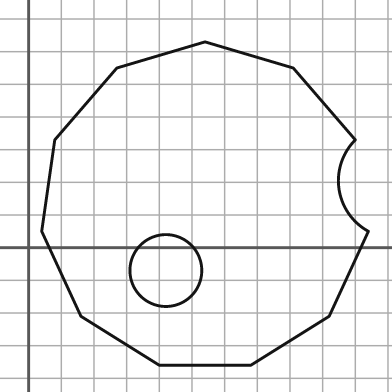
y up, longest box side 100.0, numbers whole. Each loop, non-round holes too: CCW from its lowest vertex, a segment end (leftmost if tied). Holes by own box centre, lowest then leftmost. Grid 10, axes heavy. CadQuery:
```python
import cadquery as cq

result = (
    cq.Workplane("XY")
    .moveTo(40.0, -36.0)
    .lineTo(68.0, -36.0)
    .lineTo(92.0, -21.0)
    .lineTo(104.0, 5.0)
    .threePointArc((95.0, 18.0), (100.0, 33.0))
    .lineTo(81.0, 55.0)
    .lineTo(54.0, 63.0)
    .lineTo(27.0, 55.0)
    .lineTo(8.0, 33.0)
    .lineTo(4.0, 5.0)
    .lineTo(16.0, -21.0)
    .close()
    .moveTo(42.0, -7.0)
    .circle(11.0)
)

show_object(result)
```